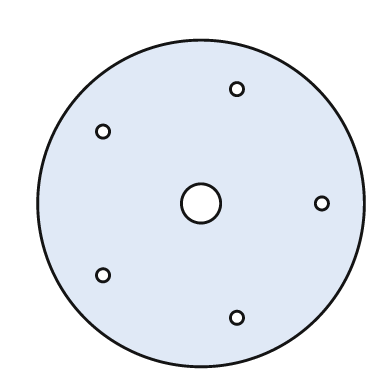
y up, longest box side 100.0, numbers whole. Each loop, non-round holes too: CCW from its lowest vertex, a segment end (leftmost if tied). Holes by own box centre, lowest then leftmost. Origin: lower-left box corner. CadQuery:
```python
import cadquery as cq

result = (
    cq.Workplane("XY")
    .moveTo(50.0, 50.0)
    .circle(50.0)
    .moveTo(61.0, 15.0)
    .circle(2.0)
    .moveTo(20.0, 28.0)
    .circle(2.0)
    .moveTo(50.0, 50.0)
    .circle(6.0)
    .moveTo(87.0, 50.0)
    .circle(2.0)
    .moveTo(20.0, 72.0)
    .circle(2.0)
    .moveTo(61.0, 85.0)
    .circle(2.0)
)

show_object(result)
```